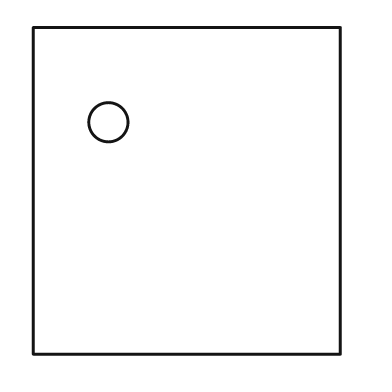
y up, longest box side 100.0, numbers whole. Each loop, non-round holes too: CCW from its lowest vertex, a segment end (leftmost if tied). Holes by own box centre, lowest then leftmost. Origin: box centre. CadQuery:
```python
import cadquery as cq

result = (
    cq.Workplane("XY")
    .moveTo(-47.0, -50.0)
    .lineTo(47.0, -50.0)
    .lineTo(47.0, 50.0)
    .lineTo(-47.0, 50.0)
    .close()
    .moveTo(-24.0, 21.0)
    .circle(6.0)
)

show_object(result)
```